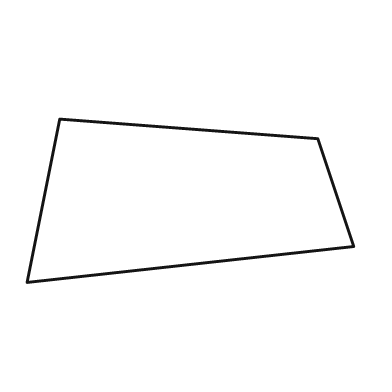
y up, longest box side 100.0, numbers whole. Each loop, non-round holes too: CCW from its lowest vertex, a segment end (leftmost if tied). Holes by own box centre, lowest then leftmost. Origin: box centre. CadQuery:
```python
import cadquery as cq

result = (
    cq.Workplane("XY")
    .moveTo(-50.0, -25.0)
    .lineTo(50.0, -14.0)
    .lineTo(39.0, 19.0)
    .lineTo(-40.0, 25.0)
    .close()
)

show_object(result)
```